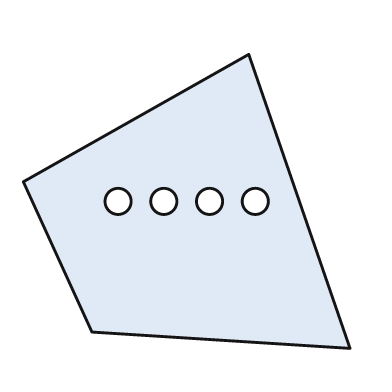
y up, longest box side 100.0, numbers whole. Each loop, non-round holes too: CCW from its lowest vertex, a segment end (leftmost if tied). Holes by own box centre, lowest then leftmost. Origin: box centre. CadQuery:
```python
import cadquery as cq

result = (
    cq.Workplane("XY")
    .moveTo(50.0, -45.0)
    .lineTo(19.0, 45.0)
    .lineTo(-50.0, 6.0)
    .lineTo(-29.0, -40.0)
    .close()
    .moveTo(-21.0, 0.0)
    .circle(4.0)
    .moveTo(-7.0, 0.0)
    .circle(4.0)
    .moveTo(7.0, 0.0)
    .circle(4.0)
    .moveTo(21.0, 0.0)
    .circle(4.0)
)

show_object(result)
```